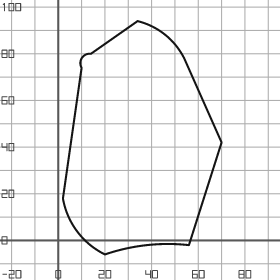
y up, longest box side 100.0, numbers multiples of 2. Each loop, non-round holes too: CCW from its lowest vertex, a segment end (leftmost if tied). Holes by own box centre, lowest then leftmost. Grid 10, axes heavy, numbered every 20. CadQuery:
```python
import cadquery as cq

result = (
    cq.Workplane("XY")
    .moveTo(20.0, -6.0)
    .threePointArc((38.0, -2.0), (56.0, -2.0))
    .lineTo(70.0, 42.0)
    .lineTo(54.0, 78.0)
    .threePointArc((46.0, 88.0), (34.0, 94.0))
    .lineTo(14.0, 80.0)
    .threePointArc((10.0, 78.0), (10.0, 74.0))
    .lineTo(2.0, 18.0)
    .threePointArc((8.0, 4.0), (20.0, -6.0))
    .close()
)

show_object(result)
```